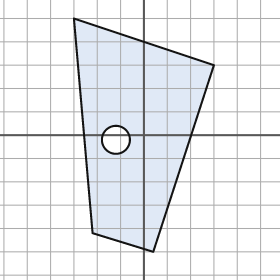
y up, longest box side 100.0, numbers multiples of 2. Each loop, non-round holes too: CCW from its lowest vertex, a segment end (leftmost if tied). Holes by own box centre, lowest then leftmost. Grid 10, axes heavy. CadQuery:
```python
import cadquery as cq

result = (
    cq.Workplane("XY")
    .moveTo(4.0, -50.0)
    .lineTo(30.0, 30.0)
    .lineTo(-30.0, 50.0)
    .lineTo(-22.0, -42.0)
    .close()
    .moveTo(-12.0, -2.0)
    .circle(6.0)
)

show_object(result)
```